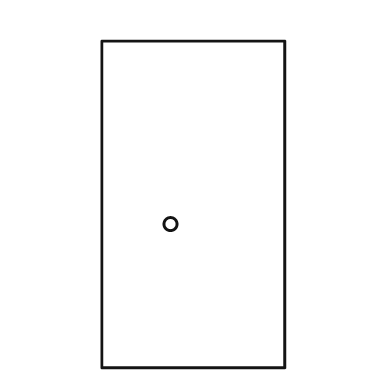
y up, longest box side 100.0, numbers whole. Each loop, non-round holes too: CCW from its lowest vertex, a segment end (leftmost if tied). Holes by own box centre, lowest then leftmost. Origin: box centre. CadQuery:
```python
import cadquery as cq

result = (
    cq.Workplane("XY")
    .moveTo(-28.0, -50.0)
    .lineTo(28.0, -50.0)
    .lineTo(28.0, 50.0)
    .lineTo(-28.0, 50.0)
    .close()
    .moveTo(-7.0, -6.0)
    .circle(2.0)
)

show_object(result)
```